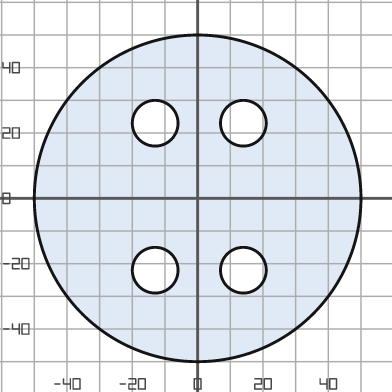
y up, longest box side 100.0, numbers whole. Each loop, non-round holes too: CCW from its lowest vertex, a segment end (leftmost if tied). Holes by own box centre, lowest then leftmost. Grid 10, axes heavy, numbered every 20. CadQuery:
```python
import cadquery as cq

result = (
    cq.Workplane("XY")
    .moveTo(0.0, 0.0)
    .circle(50.0)
    .moveTo(-13.0, -22.0)
    .circle(7.0)
    .moveTo(14.0, -22.0)
    .circle(7.0)
    .moveTo(-13.0, 23.0)
    .circle(7.0)
    .moveTo(14.0, 23.0)
    .circle(7.0)
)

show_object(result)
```